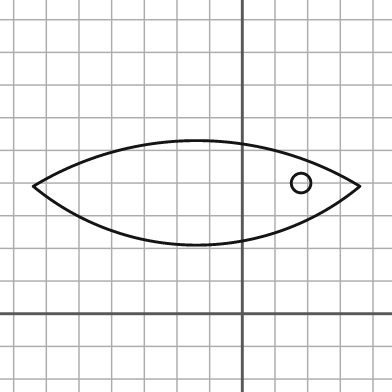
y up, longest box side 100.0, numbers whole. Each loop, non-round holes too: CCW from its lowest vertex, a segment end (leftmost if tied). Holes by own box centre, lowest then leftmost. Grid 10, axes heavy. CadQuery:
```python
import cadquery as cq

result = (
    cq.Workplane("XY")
    .moveTo(-64.0, 39.0)
    .threePointArc((-14.0, 21.0), (36.0, 39.0))
    .threePointArc((-14.0, 53.0), (-64.0, 39.0))
    .close()
    .moveTo(18.0, 40.0)
    .circle(3.0)
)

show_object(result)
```